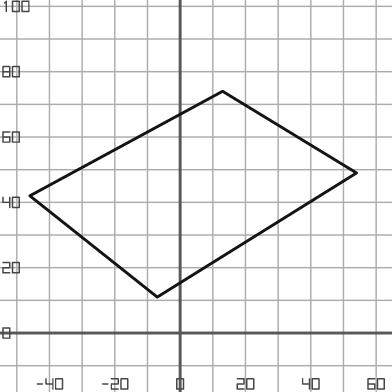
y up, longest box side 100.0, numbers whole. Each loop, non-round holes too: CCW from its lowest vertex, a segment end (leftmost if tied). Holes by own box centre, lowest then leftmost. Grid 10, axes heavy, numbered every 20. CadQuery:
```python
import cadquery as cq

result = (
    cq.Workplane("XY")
    .moveTo(-7.0, 11.0)
    .lineTo(54.0, 49.0)
    .lineTo(13.0, 74.0)
    .lineTo(-46.0, 42.0)
    .close()
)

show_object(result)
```